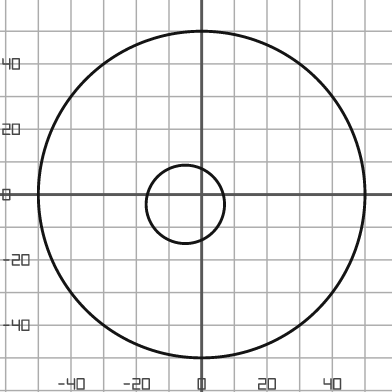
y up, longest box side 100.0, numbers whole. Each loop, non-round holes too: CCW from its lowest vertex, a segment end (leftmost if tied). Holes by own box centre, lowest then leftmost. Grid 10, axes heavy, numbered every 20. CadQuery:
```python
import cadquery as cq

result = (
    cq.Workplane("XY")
    .moveTo(0.0, 0.0)
    .circle(50.0)
    .moveTo(-5.0, -3.0)
    .circle(12.0)
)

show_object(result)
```